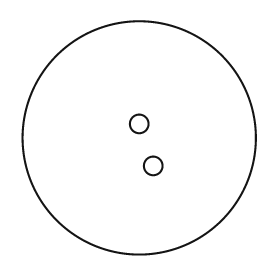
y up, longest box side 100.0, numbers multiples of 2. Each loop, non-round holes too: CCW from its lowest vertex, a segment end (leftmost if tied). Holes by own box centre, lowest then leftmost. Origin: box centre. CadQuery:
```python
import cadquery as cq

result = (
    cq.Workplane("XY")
    .moveTo(0.0, 0.0)
    .circle(50.0)
    .moveTo(6.0, -12.0)
    .circle(4.0)
    .moveTo(0.0, 6.0)
    .circle(4.0)
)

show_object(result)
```